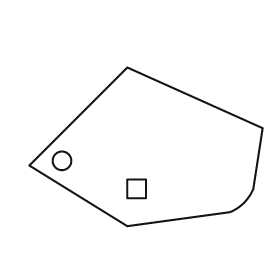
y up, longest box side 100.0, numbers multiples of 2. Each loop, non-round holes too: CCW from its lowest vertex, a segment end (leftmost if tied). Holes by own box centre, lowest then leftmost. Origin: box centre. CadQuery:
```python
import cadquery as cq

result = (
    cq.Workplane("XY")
    .moveTo(-8.0, -34.0)
    .lineTo(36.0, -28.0)
    .threePointArc((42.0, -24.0), (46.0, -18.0))
    .lineTo(50.0, 8.0)
    .lineTo(-8.0, 34.0)
    .lineTo(-50.0, -8.0)
    .close()
    .moveTo(-8.0, -22.0)
    .lineTo(0.0, -22.0)
    .lineTo(0.0, -14.0)
    .lineTo(-8.0, -14.0)
    .close()
    .moveTo(-36.0, -6.0)
    .circle(4.0)
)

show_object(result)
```